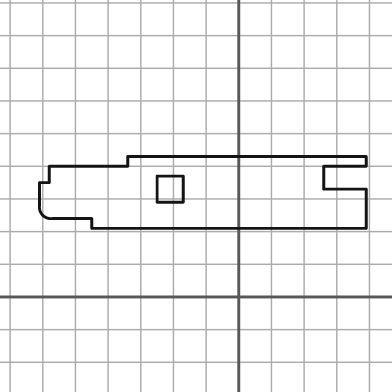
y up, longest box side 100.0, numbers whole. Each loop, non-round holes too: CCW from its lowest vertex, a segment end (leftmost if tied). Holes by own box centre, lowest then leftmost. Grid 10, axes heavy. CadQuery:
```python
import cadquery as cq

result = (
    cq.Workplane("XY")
    .moveTo(-45.0, 21.0)
    .lineTo(39.0, 21.0)
    .lineTo(39.0, 33.0)
    .lineTo(26.0, 33.0)
    .lineTo(26.0, 40.0)
    .lineTo(39.0, 40.0)
    .lineTo(39.0, 43.0)
    .lineTo(-34.0, 43.0)
    .lineTo(-34.0, 40.0)
    .lineTo(-58.0, 40.0)
    .lineTo(-58.0, 35.0)
    .lineTo(-61.0, 35.0)
    .lineTo(-61.0, 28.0)
    .threePointArc((-60.0, 25.0), (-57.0, 24.0))
    .lineTo(-45.0, 24.0)
    .close()
    .moveTo(-25.0, 29.0)
    .lineTo(-17.0, 29.0)
    .lineTo(-17.0, 37.0)
    .lineTo(-25.0, 37.0)
    .close()
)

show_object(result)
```